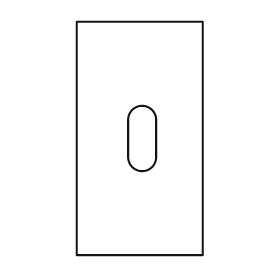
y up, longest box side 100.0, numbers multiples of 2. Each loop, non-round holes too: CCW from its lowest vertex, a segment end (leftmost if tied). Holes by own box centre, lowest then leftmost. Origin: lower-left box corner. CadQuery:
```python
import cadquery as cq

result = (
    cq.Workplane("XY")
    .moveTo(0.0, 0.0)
    .lineTo(54.0, 0.0)
    .lineTo(54.0, 100.0)
    .lineTo(0.0, 100.0)
    .close()
    .moveTo(22.0, 42.0)
    .threePointArc((28.0, 36.0), (34.0, 42.0))
    .lineTo(34.0, 58.0)
    .threePointArc((28.0, 64.0), (22.0, 58.0))
    .close()
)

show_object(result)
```